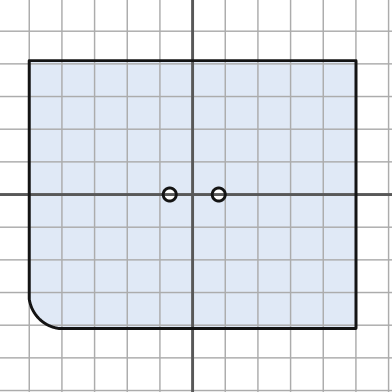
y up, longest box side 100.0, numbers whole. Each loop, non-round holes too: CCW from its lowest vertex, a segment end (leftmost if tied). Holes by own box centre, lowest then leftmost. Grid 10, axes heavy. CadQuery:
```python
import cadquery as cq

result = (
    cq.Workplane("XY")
    .moveTo(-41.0, -41.0)
    .lineTo(50.0, -41.0)
    .lineTo(50.0, 41.0)
    .lineTo(-50.0, 41.0)
    .lineTo(-50.0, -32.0)
    .threePointArc((-47.0, -38.0), (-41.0, -41.0))
    .close()
    .moveTo(-7.0, 0.0)
    .circle(2.0)
    .moveTo(8.0, 0.0)
    .circle(2.0)
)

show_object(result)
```